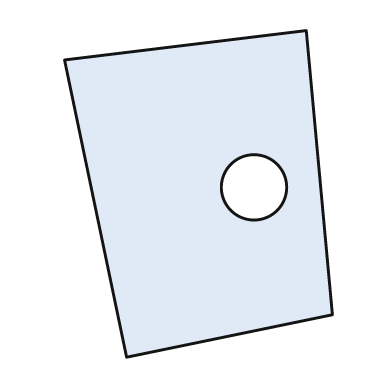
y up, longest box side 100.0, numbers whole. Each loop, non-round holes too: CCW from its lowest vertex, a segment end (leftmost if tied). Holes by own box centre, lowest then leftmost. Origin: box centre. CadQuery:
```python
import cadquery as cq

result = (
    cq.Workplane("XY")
    .moveTo(-22.0, -50.0)
    .lineTo(41.0, -37.0)
    .lineTo(33.0, 50.0)
    .lineTo(-41.0, 41.0)
    .close()
    .moveTo(17.0, 2.0)
    .circle(10.0)
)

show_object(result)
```